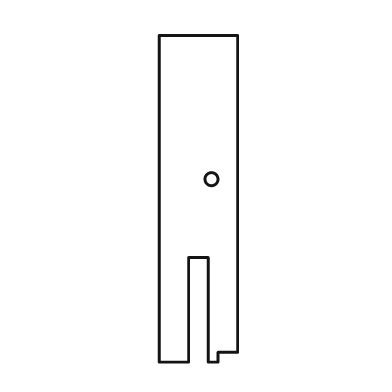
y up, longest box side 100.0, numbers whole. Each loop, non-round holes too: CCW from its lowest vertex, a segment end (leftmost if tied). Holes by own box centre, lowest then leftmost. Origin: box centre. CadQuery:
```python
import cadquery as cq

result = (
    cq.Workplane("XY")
    .moveTo(-12.0, -50.0)
    .lineTo(-3.0, -50.0)
    .lineTo(-3.0, -18.0)
    .lineTo(3.0, -18.0)
    .lineTo(3.0, -50.0)
    .lineTo(6.0, -50.0)
    .lineTo(6.0, -47.0)
    .lineTo(12.0, -47.0)
    .lineTo(12.0, 50.0)
    .lineTo(-12.0, 50.0)
    .close()
    .moveTo(4.0, 6.0)
    .circle(2.0)
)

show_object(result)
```